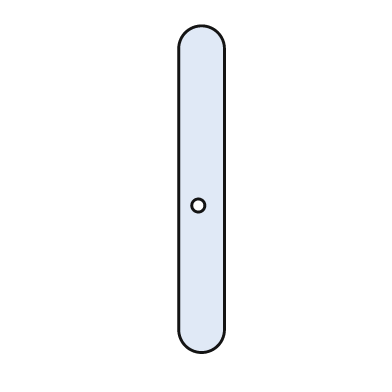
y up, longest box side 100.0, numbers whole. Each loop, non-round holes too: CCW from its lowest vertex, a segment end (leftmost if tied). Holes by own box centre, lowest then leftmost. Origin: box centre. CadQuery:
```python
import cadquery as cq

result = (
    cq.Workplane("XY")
    .moveTo(-7.0, -43.0)
    .threePointArc((0.0, -50.0), (7.0, -43.0))
    .lineTo(7.0, 43.0)
    .threePointArc((0.0, 50.0), (-7.0, 43.0))
    .close()
    .moveTo(-1.0, -5.0)
    .circle(2.0)
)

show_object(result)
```